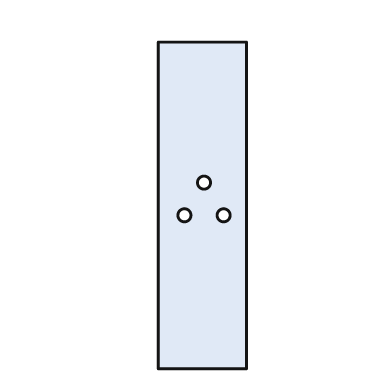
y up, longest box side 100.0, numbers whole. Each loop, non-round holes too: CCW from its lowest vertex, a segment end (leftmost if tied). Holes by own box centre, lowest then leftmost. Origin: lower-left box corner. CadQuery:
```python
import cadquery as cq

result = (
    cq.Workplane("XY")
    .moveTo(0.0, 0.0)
    .lineTo(27.0, 0.0)
    .lineTo(27.0, 100.0)
    .lineTo(0.0, 100.0)
    .close()
    .moveTo(8.0, 47.0)
    .circle(2.0)
    .moveTo(20.0, 47.0)
    .circle(2.0)
    .moveTo(14.0, 57.0)
    .circle(2.0)
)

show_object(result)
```